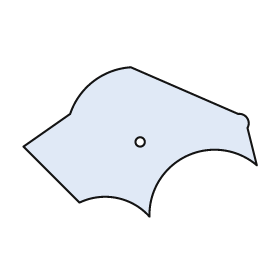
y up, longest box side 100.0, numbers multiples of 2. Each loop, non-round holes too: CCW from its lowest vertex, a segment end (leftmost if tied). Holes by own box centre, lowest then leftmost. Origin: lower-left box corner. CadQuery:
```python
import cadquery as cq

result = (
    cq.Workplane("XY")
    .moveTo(54.0, 0.0)
    .threePointArc((70.0, 26.0), (100.0, 22.0))
    .lineTo(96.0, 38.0)
    .threePointArc((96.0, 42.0), (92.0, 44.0))
    .lineTo(46.0, 64.0)
    .threePointArc((30.0, 58.0), (20.0, 44.0))
    .lineTo(0.0, 30.0)
    .lineTo(24.0, 6.0)
    .threePointArc((40.0, 8.0), (54.0, 0.0))
    .close()
    .moveTo(50.0, 32.0)
    .circle(2.0)
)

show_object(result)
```